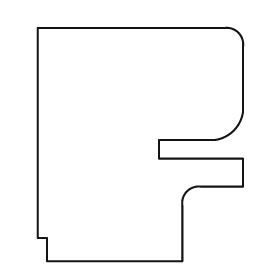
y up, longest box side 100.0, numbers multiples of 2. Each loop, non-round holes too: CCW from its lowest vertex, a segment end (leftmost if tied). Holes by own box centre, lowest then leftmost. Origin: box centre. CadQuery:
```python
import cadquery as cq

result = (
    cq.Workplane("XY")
    .moveTo(-40.0, -50.0)
    .lineTo(18.0, -50.0)
    .lineTo(18.0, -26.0)
    .threePointArc((20.0, -20.0), (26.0, -18.0))
    .lineTo(44.0, -18.0)
    .lineTo(44.0, -6.0)
    .lineTo(8.0, -6.0)
    .lineTo(8.0, 2.0)
    .lineTo(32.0, 2.0)
    .threePointArc((40.0, 6.0), (44.0, 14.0))
    .lineTo(44.0, 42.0)
    .threePointArc((42.0, 48.0), (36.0, 50.0))
    .lineTo(-44.0, 50.0)
    .lineTo(-44.0, -40.0)
    .lineTo(-40.0, -40.0)
    .close()
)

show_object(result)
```